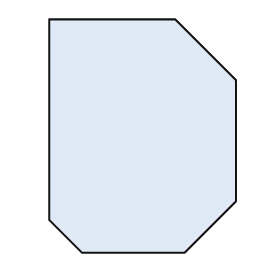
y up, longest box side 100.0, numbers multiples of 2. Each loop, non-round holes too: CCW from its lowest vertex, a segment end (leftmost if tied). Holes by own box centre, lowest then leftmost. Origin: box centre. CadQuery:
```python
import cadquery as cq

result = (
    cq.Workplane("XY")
    .moveTo(-26.0, -50.0)
    .lineTo(18.0, -50.0)
    .lineTo(40.0, -28.0)
    .lineTo(40.0, 24.0)
    .lineTo(14.0, 50.0)
    .lineTo(-40.0, 50.0)
    .lineTo(-40.0, -36.0)
    .close()
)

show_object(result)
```